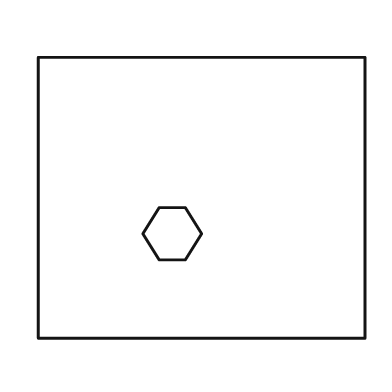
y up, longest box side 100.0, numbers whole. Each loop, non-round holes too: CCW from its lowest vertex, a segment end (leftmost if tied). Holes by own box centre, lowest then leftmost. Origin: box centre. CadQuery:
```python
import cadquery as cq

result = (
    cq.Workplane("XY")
    .moveTo(-50.0, -43.0)
    .lineTo(50.0, -43.0)
    .lineTo(50.0, 43.0)
    .lineTo(-50.0, 43.0)
    .close()
    .moveTo(-13.0, -19.0)
    .lineTo(-5.0, -19.0)
    .lineTo(0.0, -11.0)
    .lineTo(-5.0, -3.0)
    .lineTo(-13.0, -3.0)
    .lineTo(-18.0, -11.0)
    .close()
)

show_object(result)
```